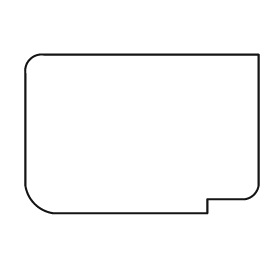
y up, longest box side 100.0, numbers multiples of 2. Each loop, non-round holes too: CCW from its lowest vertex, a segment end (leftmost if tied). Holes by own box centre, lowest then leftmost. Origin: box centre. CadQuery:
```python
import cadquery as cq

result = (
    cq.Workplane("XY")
    .moveTo(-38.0, -34.0)
    .lineTo(28.0, -34.0)
    .lineTo(28.0, -28.0)
    .lineTo(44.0, -28.0)
    .threePointArc((48.0, -26.0), (50.0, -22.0))
    .lineTo(50.0, 34.0)
    .lineTo(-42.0, 34.0)
    .threePointArc((-48.0, 32.0), (-50.0, 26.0))
    .lineTo(-50.0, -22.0)
    .threePointArc((-46.0, -30.0), (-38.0, -34.0))
    .close()
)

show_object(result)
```